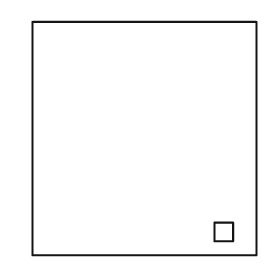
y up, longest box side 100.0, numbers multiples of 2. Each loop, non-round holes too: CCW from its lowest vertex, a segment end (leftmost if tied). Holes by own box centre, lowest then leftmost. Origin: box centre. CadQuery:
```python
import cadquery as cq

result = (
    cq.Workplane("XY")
    .moveTo(-48.0, -50.0)
    .lineTo(48.0, -50.0)
    .lineTo(48.0, 50.0)
    .lineTo(-48.0, 50.0)
    .close()
    .moveTo(30.0, -44.0)
    .lineTo(38.0, -44.0)
    .lineTo(38.0, -36.0)
    .lineTo(30.0, -36.0)
    .close()
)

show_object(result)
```